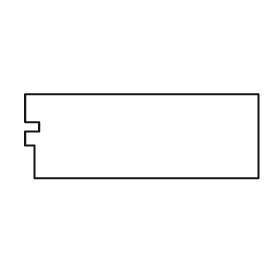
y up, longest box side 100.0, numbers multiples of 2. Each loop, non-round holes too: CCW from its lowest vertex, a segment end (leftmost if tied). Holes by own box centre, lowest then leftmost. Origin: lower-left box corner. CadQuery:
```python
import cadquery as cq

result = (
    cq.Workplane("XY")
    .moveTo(4.0, 0.0)
    .lineTo(100.0, 0.0)
    .lineTo(100.0, 36.0)
    .lineTo(0.0, 36.0)
    .lineTo(0.0, 24.0)
    .lineTo(6.0, 24.0)
    .lineTo(6.0, 20.0)
    .lineTo(0.0, 20.0)
    .lineTo(0.0, 14.0)
    .lineTo(4.0, 14.0)
    .close()
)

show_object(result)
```